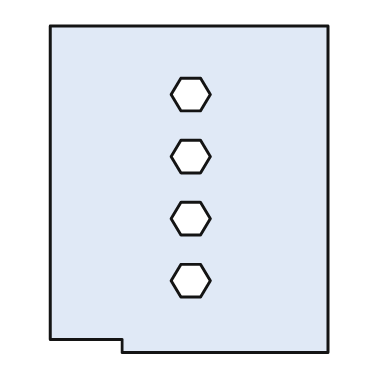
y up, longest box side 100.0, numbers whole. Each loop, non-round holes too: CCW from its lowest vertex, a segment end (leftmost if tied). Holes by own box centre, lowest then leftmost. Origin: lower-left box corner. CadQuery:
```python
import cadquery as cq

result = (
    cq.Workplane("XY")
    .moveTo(22.0, 0.0)
    .lineTo(85.0, 0.0)
    .lineTo(85.0, 100.0)
    .lineTo(0.0, 100.0)
    .lineTo(0.0, 4.0)
    .lineTo(22.0, 4.0)
    .close()
    .moveTo(40.0, 17.0)
    .lineTo(46.0, 17.0)
    .lineTo(49.0, 22.0)
    .lineTo(46.0, 27.0)
    .lineTo(40.0, 27.0)
    .lineTo(37.0, 22.0)
    .close()
    .moveTo(40.0, 36.0)
    .lineTo(46.0, 36.0)
    .lineTo(49.0, 41.0)
    .lineTo(46.0, 46.0)
    .lineTo(40.0, 46.0)
    .lineTo(37.0, 41.0)
    .close()
    .moveTo(40.0, 55.0)
    .lineTo(46.0, 55.0)
    .lineTo(49.0, 60.0)
    .lineTo(46.0, 65.0)
    .lineTo(40.0, 65.0)
    .lineTo(37.0, 60.0)
    .close()
    .moveTo(40.0, 74.0)
    .lineTo(46.0, 74.0)
    .lineTo(49.0, 79.0)
    .lineTo(46.0, 84.0)
    .lineTo(40.0, 84.0)
    .lineTo(37.0, 79.0)
    .close()
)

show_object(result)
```